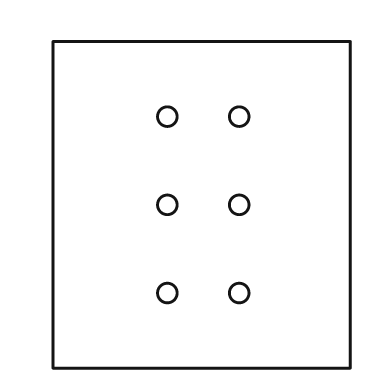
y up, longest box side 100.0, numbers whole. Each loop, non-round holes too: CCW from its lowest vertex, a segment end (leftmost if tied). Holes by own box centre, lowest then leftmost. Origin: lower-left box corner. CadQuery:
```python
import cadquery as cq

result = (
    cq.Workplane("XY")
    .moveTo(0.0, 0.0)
    .lineTo(91.0, 0.0)
    .lineTo(91.0, 100.0)
    .lineTo(0.0, 100.0)
    .close()
    .moveTo(35.0, 23.0)
    .circle(3.0)
    .moveTo(57.0, 23.0)
    .circle(3.0)
    .moveTo(35.0, 50.0)
    .circle(3.0)
    .moveTo(57.0, 50.0)
    .circle(3.0)
    .moveTo(35.0, 77.0)
    .circle(3.0)
    .moveTo(57.0, 77.0)
    .circle(3.0)
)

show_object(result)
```